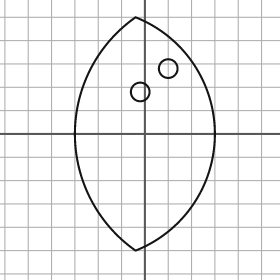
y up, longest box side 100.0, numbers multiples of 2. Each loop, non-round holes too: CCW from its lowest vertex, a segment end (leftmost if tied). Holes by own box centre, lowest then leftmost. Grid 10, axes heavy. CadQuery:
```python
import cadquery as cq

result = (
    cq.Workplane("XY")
    .moveTo(-4.0, -50.0)
    .threePointArc((30.0, 0.0), (-4.0, 50.0))
    .threePointArc((-30.0, 0.0), (-4.0, -50.0))
    .close()
    .moveTo(-2.0, 18.0)
    .circle(4.0)
    .moveTo(10.0, 28.0)
    .circle(4.0)
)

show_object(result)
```